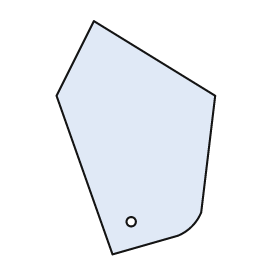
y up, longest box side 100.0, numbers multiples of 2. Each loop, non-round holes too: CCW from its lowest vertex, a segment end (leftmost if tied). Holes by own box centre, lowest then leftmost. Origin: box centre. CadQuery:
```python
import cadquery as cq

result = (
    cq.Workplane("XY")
    .moveTo(-10.0, -50.0)
    .lineTo(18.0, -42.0)
    .threePointArc((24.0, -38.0), (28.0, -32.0))
    .lineTo(34.0, 18.0)
    .lineTo(-18.0, 50.0)
    .lineTo(-34.0, 18.0)
    .close()
    .moveTo(-2.0, -36.0)
    .circle(2.0)
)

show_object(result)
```